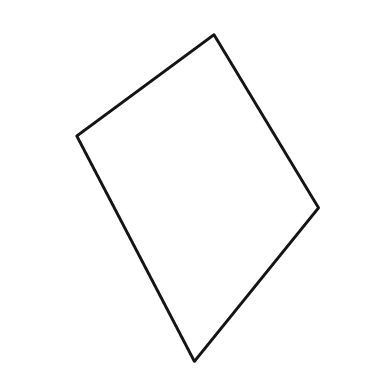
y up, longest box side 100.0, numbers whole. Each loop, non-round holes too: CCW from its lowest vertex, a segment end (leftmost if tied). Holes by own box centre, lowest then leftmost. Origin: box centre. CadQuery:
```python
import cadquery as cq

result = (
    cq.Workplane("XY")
    .moveTo(-1.0, -50.0)
    .lineTo(37.0, -3.0)
    .lineTo(5.0, 50.0)
    .lineTo(-37.0, 19.0)
    .close()
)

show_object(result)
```